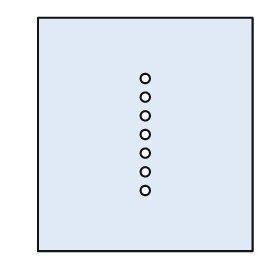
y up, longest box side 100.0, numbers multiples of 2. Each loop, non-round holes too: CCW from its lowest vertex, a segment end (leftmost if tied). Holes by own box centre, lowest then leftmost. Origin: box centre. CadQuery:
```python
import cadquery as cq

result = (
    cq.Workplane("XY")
    .moveTo(-46.0, -50.0)
    .lineTo(46.0, -50.0)
    .lineTo(46.0, 50.0)
    .lineTo(-46.0, 50.0)
    .close()
    .moveTo(0.0, -24.0)
    .circle(2.0)
    .moveTo(0.0, -16.0)
    .circle(2.0)
    .moveTo(0.0, -8.0)
    .circle(2.0)
    .moveTo(0.0, 0.0)
    .circle(2.0)
    .moveTo(0.0, 8.0)
    .circle(2.0)
    .moveTo(0.0, 16.0)
    .circle(2.0)
    .moveTo(0.0, 24.0)
    .circle(2.0)
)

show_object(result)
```